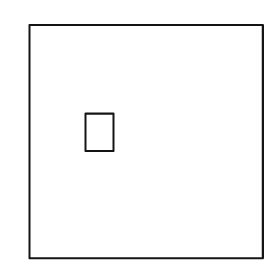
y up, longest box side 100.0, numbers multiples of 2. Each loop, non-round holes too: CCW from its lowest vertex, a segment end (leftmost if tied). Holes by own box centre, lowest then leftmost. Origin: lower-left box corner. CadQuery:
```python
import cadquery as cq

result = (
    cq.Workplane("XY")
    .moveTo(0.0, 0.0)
    .lineTo(100.0, 0.0)
    .lineTo(100.0, 100.0)
    .lineTo(0.0, 100.0)
    .close()
    .moveTo(24.0, 46.0)
    .lineTo(36.0, 46.0)
    .lineTo(36.0, 62.0)
    .lineTo(24.0, 62.0)
    .close()
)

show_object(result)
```